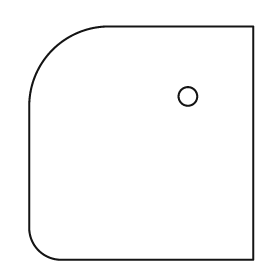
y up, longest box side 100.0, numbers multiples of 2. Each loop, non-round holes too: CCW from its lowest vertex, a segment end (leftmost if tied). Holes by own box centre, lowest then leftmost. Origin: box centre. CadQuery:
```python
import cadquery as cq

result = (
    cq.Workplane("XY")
    .moveTo(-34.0, -50.0)
    .lineTo(48.0, -50.0)
    .lineTo(48.0, 50.0)
    .lineTo(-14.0, 50.0)
    .threePointArc((-38.0, 40.0), (-48.0, 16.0))
    .lineTo(-48.0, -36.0)
    .threePointArc((-44.0, -46.0), (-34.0, -50.0))
    .close()
    .moveTo(20.0, 20.0)
    .circle(4.0)
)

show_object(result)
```